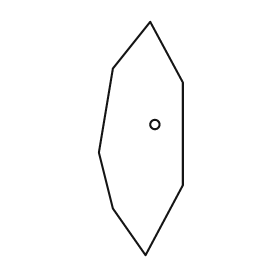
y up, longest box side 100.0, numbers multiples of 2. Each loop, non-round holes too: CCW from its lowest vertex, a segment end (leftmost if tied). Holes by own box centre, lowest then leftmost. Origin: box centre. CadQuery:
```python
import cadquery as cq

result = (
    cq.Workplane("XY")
    .moveTo(2.0, -50.0)
    .lineTo(18.0, -20.0)
    .lineTo(18.0, 24.0)
    .lineTo(4.0, 50.0)
    .lineTo(-12.0, 30.0)
    .lineTo(-18.0, -6.0)
    .lineTo(-12.0, -30.0)
    .close()
    .moveTo(6.0, 6.0)
    .circle(2.0)
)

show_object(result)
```